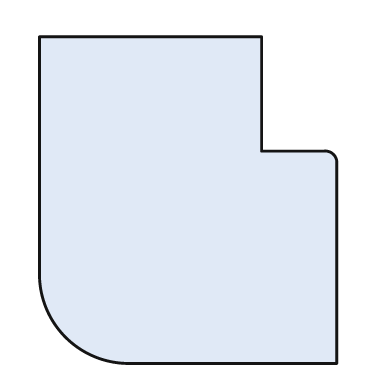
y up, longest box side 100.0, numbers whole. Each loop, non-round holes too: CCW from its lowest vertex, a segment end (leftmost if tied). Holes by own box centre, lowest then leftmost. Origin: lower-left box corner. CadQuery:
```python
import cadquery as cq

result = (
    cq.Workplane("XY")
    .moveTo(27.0, 0.0)
    .lineTo(91.0, 0.0)
    .lineTo(91.0, 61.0)
    .threePointArc((90.0, 64.0), (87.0, 65.0))
    .lineTo(68.0, 65.0)
    .lineTo(68.0, 100.0)
    .lineTo(0.0, 100.0)
    .lineTo(0.0, 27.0)
    .threePointArc((8.0, 8.0), (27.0, 0.0))
    .close()
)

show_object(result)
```